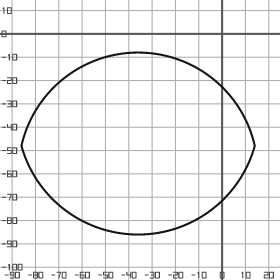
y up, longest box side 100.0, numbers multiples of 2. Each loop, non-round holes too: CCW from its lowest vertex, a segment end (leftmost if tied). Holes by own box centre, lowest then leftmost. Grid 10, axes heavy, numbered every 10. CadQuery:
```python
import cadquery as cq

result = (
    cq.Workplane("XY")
    .moveTo(-86.0, -48.0)
    .threePointArc((-36.0, -86.0), (14.0, -48.0))
    .threePointArc((-36.0, -8.0), (-86.0, -48.0))
    .close()
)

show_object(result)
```